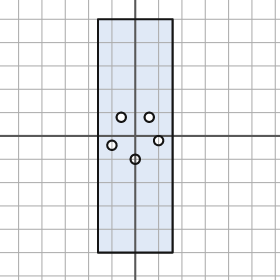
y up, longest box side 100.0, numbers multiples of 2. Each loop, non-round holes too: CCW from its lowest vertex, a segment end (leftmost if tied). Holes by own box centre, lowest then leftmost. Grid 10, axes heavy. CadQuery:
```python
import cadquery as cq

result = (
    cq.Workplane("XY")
    .moveTo(-16.0, -50.0)
    .lineTo(16.0, -50.0)
    .lineTo(16.0, 50.0)
    .lineTo(-16.0, 50.0)
    .close()
    .moveTo(0.0, -10.0)
    .circle(2.0)
    .moveTo(-10.0, -4.0)
    .circle(2.0)
    .moveTo(10.0, -2.0)
    .circle(2.0)
    .moveTo(-6.0, 8.0)
    .circle(2.0)
    .moveTo(6.0, 8.0)
    .circle(2.0)
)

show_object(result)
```